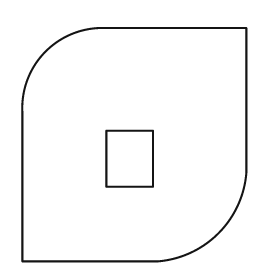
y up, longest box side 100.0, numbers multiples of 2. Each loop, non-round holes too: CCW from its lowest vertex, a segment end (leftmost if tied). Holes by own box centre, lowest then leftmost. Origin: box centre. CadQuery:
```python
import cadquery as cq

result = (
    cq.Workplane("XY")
    .moveTo(-48.0, -50.0)
    .lineTo(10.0, -50.0)
    .threePointArc((36.0, -38.0), (48.0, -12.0))
    .lineTo(48.0, 50.0)
    .lineTo(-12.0, 50.0)
    .threePointArc((-38.0, 40.0), (-48.0, 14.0))
    .close()
    .moveTo(-12.0, -18.0)
    .lineTo(8.0, -18.0)
    .lineTo(8.0, 6.0)
    .lineTo(-12.0, 6.0)
    .close()
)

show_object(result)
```